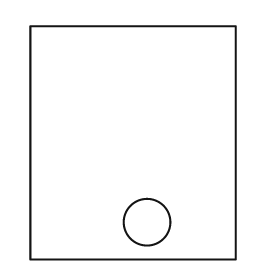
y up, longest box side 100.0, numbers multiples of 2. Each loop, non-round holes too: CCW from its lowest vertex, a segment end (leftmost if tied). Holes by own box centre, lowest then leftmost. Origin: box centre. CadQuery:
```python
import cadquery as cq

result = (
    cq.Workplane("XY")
    .moveTo(-44.0, -50.0)
    .lineTo(44.0, -50.0)
    .lineTo(44.0, 50.0)
    .lineTo(-44.0, 50.0)
    .close()
    .moveTo(6.0, -34.0)
    .circle(10.0)
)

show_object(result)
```